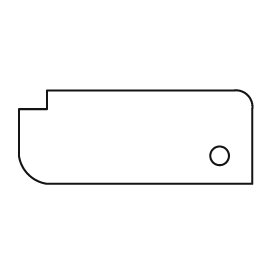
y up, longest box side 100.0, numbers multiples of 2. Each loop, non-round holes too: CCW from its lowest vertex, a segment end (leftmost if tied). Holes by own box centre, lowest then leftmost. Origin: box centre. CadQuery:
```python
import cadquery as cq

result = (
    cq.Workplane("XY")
    .moveTo(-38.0, -20.0)
    .lineTo(50.0, -20.0)
    .lineTo(50.0, 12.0)
    .threePointArc((48.0, 18.0), (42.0, 20.0))
    .lineTo(-38.0, 20.0)
    .lineTo(-38.0, 12.0)
    .lineTo(-50.0, 12.0)
    .lineTo(-50.0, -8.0)
    .threePointArc((-46.0, -16.0), (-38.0, -20.0))
    .close()
    .moveTo(36.0, -8.0)
    .circle(4.0)
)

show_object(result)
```